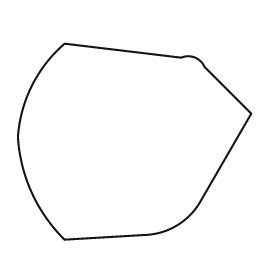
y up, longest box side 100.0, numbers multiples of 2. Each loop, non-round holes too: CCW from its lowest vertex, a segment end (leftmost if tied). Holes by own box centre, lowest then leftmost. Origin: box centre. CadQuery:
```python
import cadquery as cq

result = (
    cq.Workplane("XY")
    .moveTo(-30.0, -42.0)
    .lineTo(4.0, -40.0)
    .threePointArc((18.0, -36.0), (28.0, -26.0))
    .lineTo(50.0, 12.0)
    .lineTo(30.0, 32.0)
    .threePointArc((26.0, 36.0), (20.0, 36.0))
    .lineTo(-30.0, 42.0)
    .threePointArc((-44.0, 24.0), (-50.0, 2.0))
    .threePointArc((-44.0, -22.0), (-30.0, -42.0))
    .close()
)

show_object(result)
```